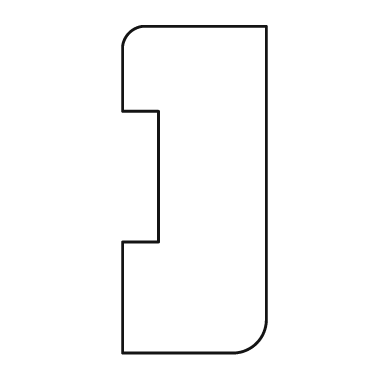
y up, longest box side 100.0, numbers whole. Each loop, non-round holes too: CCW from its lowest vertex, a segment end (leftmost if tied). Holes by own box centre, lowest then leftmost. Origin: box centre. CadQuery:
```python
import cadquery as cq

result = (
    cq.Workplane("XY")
    .moveTo(-22.0, -50.0)
    .lineTo(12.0, -50.0)
    .threePointArc((19.0, -47.0), (22.0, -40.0))
    .lineTo(22.0, 50.0)
    .lineTo(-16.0, 50.0)
    .threePointArc((-20.0, 48.0), (-22.0, 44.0))
    .lineTo(-22.0, 24.0)
    .lineTo(-11.0, 24.0)
    .lineTo(-11.0, -16.0)
    .lineTo(-22.0, -16.0)
    .close()
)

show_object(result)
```